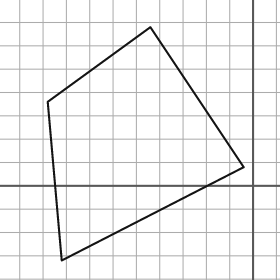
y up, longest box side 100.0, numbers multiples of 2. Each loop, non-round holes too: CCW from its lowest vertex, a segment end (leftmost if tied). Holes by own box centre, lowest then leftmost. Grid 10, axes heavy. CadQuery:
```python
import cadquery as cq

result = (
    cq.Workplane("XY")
    .moveTo(-82.0, -32.0)
    .lineTo(-4.0, 8.0)
    .lineTo(-44.0, 68.0)
    .lineTo(-88.0, 36.0)
    .close()
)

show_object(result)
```